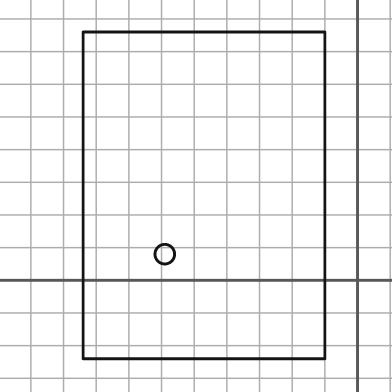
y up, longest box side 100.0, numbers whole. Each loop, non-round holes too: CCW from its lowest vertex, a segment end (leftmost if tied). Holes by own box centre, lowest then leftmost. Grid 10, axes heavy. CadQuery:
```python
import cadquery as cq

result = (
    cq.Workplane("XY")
    .moveTo(-84.0, -24.0)
    .lineTo(-10.0, -24.0)
    .lineTo(-10.0, 76.0)
    .lineTo(-84.0, 76.0)
    .close()
    .moveTo(-59.0, 8.0)
    .circle(3.0)
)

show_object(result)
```